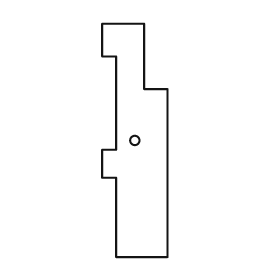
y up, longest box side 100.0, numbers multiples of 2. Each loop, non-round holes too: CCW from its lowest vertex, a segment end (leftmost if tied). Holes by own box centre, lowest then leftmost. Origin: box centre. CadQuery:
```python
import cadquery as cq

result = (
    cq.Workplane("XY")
    .moveTo(-8.0, -50.0)
    .lineTo(14.0, -50.0)
    .lineTo(14.0, 22.0)
    .lineTo(4.0, 22.0)
    .lineTo(4.0, 50.0)
    .lineTo(-14.0, 50.0)
    .lineTo(-14.0, 36.0)
    .lineTo(-8.0, 36.0)
    .lineTo(-8.0, -4.0)
    .lineTo(-14.0, -4.0)
    .lineTo(-14.0, -16.0)
    .lineTo(-8.0, -16.0)
    .close()
    .moveTo(0.0, 0.0)
    .circle(2.0)
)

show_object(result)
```